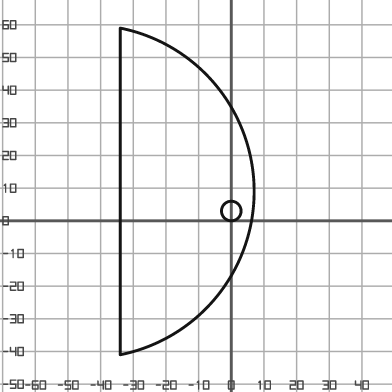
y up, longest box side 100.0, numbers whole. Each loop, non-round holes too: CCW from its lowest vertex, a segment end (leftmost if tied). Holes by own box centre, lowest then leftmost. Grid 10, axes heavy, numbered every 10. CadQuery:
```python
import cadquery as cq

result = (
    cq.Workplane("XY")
    .moveTo(-34.0, -41.0)
    .threePointArc((7.0, 9.0), (-34.0, 59.0))
    .close()
    .moveTo(0.0, 3.0)
    .circle(3.0)
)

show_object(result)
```